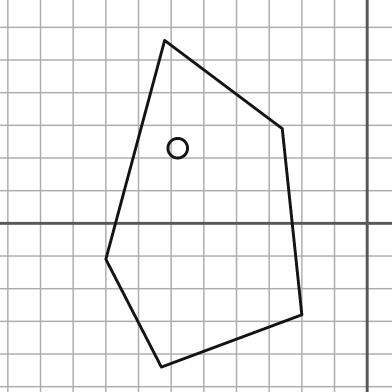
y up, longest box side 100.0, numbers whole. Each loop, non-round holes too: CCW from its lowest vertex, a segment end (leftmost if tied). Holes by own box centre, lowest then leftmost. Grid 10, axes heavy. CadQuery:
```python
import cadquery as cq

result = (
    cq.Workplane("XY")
    .moveTo(-63.0, -44.0)
    .lineTo(-20.0, -28.0)
    .lineTo(-26.0, 29.0)
    .lineTo(-62.0, 56.0)
    .lineTo(-80.0, -11.0)
    .close()
    .moveTo(-58.0, 23.0)
    .circle(3.0)
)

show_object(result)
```